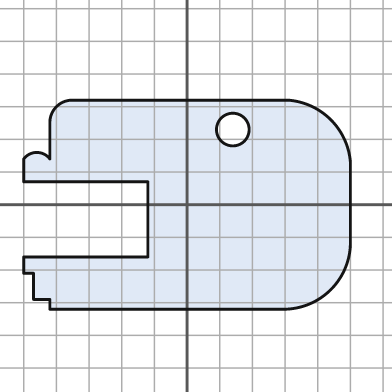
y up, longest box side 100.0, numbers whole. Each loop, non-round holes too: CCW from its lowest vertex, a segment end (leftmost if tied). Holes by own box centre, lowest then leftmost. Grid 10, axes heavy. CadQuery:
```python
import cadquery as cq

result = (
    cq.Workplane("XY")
    .moveTo(-42.0, -32.0)
    .lineTo(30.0, -32.0)
    .threePointArc((44.0, -26.0), (50.0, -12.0))
    .lineTo(50.0, 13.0)
    .threePointArc((44.0, 26.0), (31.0, 32.0))
    .lineTo(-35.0, 32.0)
    .threePointArc((-40.0, 30.0), (-42.0, 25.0))
    .lineTo(-42.0, 14.0)
    .threePointArc((-46.0, 16.0), (-50.0, 14.0))
    .lineTo(-50.0, 7.0)
    .lineTo(-12.0, 7.0)
    .lineTo(-12.0, -16.0)
    .lineTo(-50.0, -16.0)
    .lineTo(-50.0, -21.0)
    .lineTo(-47.0, -21.0)
    .lineTo(-47.0, -29.0)
    .lineTo(-42.0, -29.0)
    .close()
    .moveTo(14.0, 23.0)
    .circle(5.0)
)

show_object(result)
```